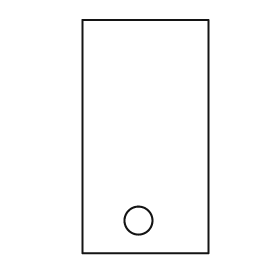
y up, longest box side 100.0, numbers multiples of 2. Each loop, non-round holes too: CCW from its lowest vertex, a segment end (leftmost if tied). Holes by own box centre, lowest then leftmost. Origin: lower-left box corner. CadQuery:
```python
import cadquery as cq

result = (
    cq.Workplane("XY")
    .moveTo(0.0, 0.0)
    .lineTo(54.0, 0.0)
    .lineTo(54.0, 100.0)
    .lineTo(0.0, 100.0)
    .close()
    .moveTo(24.0, 14.0)
    .circle(6.0)
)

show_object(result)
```